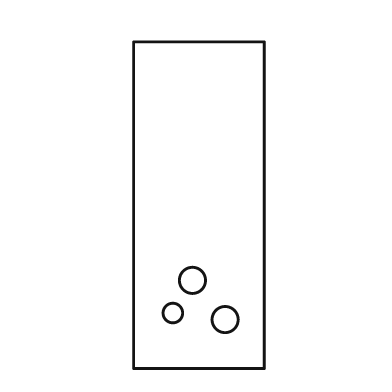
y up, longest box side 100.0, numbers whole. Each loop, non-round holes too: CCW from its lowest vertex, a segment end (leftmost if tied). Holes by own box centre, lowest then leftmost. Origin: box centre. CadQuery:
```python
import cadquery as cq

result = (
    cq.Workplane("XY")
    .moveTo(-20.0, -50.0)
    .lineTo(20.0, -50.0)
    .lineTo(20.0, 50.0)
    .lineTo(-20.0, 50.0)
    .close()
    .moveTo(8.0, -35.0)
    .circle(4.0)
    .moveTo(-8.0, -33.0)
    .circle(3.0)
    .moveTo(-2.0, -23.0)
    .circle(4.0)
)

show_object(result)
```